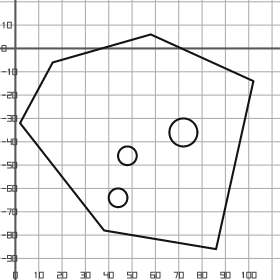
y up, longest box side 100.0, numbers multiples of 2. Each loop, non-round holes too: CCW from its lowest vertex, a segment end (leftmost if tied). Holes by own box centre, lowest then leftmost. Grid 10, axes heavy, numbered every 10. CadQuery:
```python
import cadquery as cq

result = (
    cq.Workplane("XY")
    .moveTo(86.0, -86.0)
    .lineTo(102.0, -14.0)
    .lineTo(58.0, 6.0)
    .lineTo(16.0, -6.0)
    .lineTo(2.0, -32.0)
    .lineTo(38.0, -78.0)
    .close()
    .moveTo(44.0, -64.0)
    .circle(4.0)
    .moveTo(48.0, -46.0)
    .circle(4.0)
    .moveTo(72.0, -36.0)
    .circle(6.0)
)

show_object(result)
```